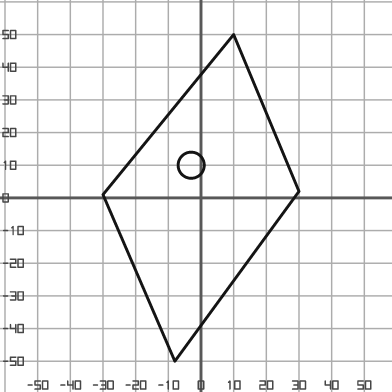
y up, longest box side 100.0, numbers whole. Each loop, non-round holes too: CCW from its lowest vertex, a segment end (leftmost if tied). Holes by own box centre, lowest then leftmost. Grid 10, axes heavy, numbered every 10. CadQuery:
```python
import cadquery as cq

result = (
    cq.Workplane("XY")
    .moveTo(-8.0, -50.0)
    .lineTo(30.0, 2.0)
    .lineTo(10.0, 50.0)
    .lineTo(-30.0, 1.0)
    .close()
    .moveTo(-3.0, 10.0)
    .circle(4.0)
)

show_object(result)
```